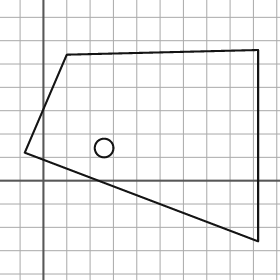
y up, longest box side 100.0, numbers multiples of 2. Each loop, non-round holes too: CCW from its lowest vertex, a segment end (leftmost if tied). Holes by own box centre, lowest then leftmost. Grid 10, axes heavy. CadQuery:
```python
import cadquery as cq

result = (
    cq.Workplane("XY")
    .moveTo(92.0, -26.0)
    .lineTo(92.0, 56.0)
    .lineTo(10.0, 54.0)
    .lineTo(-8.0, 12.0)
    .close()
    .moveTo(26.0, 14.0)
    .circle(4.0)
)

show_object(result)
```